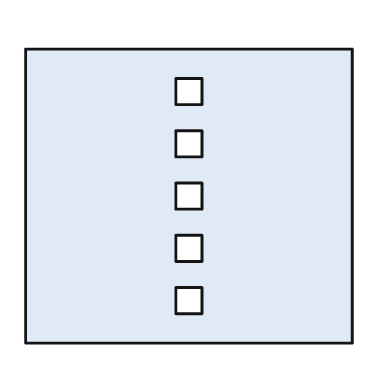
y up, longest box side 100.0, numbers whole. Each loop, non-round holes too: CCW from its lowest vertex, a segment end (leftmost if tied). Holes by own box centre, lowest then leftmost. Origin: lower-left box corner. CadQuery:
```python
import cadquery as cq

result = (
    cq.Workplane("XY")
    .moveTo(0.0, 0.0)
    .lineTo(100.0, 0.0)
    .lineTo(100.0, 90.0)
    .lineTo(0.0, 90.0)
    .close()
    .moveTo(46.0, 9.0)
    .lineTo(54.0, 9.0)
    .lineTo(54.0, 17.0)
    .lineTo(46.0, 17.0)
    .close()
    .moveTo(46.0, 25.0)
    .lineTo(54.0, 25.0)
    .lineTo(54.0, 33.0)
    .lineTo(46.0, 33.0)
    .close()
    .moveTo(46.0, 41.0)
    .lineTo(54.0, 41.0)
    .lineTo(54.0, 49.0)
    .lineTo(46.0, 49.0)
    .close()
    .moveTo(46.0, 57.0)
    .lineTo(54.0, 57.0)
    .lineTo(54.0, 65.0)
    .lineTo(46.0, 65.0)
    .close()
    .moveTo(46.0, 73.0)
    .lineTo(54.0, 73.0)
    .lineTo(54.0, 81.0)
    .lineTo(46.0, 81.0)
    .close()
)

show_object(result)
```